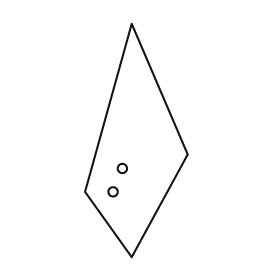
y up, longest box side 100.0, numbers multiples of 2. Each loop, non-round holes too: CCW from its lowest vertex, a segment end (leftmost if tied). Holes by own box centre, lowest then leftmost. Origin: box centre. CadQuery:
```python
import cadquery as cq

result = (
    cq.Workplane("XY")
    .moveTo(-2.0, -50.0)
    .lineTo(22.0, -6.0)
    .lineTo(-2.0, 50.0)
    .lineTo(-22.0, -22.0)
    .close()
    .moveTo(-10.0, -22.0)
    .circle(2.0)
    .moveTo(-6.0, -12.0)
    .circle(2.0)
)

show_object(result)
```